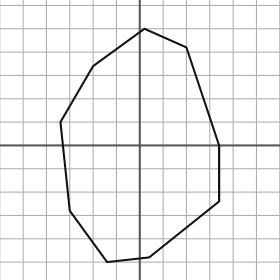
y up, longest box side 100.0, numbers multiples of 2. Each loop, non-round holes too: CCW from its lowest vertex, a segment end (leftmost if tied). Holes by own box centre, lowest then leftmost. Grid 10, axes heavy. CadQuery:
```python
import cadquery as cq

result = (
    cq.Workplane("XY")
    .moveTo(-14.0, -50.0)
    .lineTo(4.0, -48.0)
    .lineTo(34.0, -24.0)
    .lineTo(34.0, 0.0)
    .lineTo(20.0, 42.0)
    .lineTo(2.0, 50.0)
    .lineTo(-20.0, 34.0)
    .lineTo(-34.0, 10.0)
    .lineTo(-30.0, -28.0)
    .close()
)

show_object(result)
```